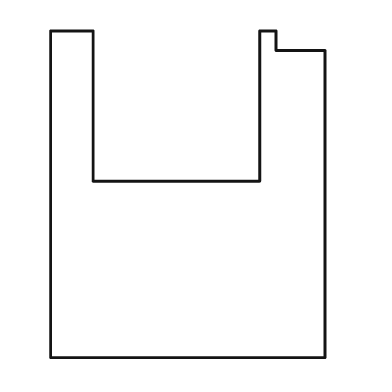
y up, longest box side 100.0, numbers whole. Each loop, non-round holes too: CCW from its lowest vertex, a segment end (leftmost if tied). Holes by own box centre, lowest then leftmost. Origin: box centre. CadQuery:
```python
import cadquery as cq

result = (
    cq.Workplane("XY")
    .moveTo(-42.0, -50.0)
    .lineTo(42.0, -50.0)
    .lineTo(42.0, 44.0)
    .lineTo(27.0, 44.0)
    .lineTo(27.0, 50.0)
    .lineTo(22.0, 50.0)
    .lineTo(22.0, 4.0)
    .lineTo(-29.0, 4.0)
    .lineTo(-29.0, 50.0)
    .lineTo(-42.0, 50.0)
    .close()
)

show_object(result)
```